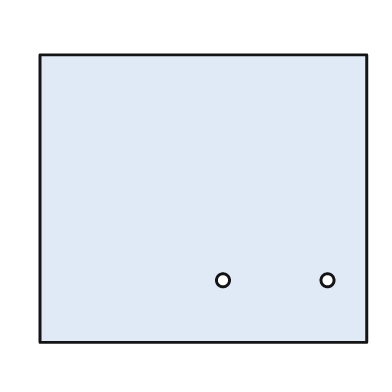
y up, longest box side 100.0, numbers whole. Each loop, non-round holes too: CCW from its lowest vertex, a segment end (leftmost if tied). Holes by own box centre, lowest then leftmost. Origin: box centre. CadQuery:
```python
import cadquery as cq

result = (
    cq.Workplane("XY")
    .moveTo(-50.0, -44.0)
    .lineTo(50.0, -44.0)
    .lineTo(50.0, 44.0)
    .lineTo(-50.0, 44.0)
    .close()
    .moveTo(6.0, -25.0)
    .circle(2.0)
    .moveTo(38.0, -25.0)
    .circle(2.0)
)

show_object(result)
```